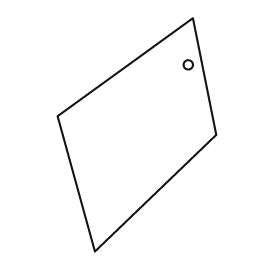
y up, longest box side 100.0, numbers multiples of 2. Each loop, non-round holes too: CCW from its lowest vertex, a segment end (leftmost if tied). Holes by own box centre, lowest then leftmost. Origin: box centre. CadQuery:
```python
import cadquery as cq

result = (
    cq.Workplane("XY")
    .moveTo(-18.0, -50.0)
    .lineTo(34.0, 0.0)
    .lineTo(24.0, 50.0)
    .lineTo(-34.0, 8.0)
    .close()
    .moveTo(22.0, 30.0)
    .circle(2.0)
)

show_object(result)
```